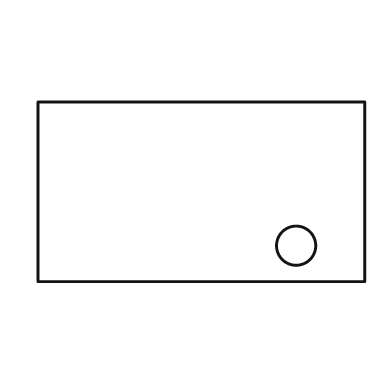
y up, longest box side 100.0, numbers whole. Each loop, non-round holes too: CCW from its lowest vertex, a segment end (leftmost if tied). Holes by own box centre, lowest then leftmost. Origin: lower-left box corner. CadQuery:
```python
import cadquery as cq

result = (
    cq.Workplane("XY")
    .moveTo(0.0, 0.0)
    .lineTo(100.0, 0.0)
    .lineTo(100.0, 55.0)
    .lineTo(0.0, 55.0)
    .close()
    .moveTo(79.0, 11.0)
    .circle(6.0)
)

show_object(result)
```